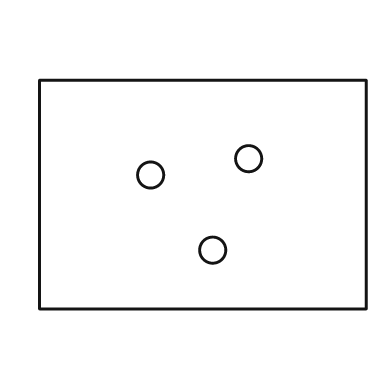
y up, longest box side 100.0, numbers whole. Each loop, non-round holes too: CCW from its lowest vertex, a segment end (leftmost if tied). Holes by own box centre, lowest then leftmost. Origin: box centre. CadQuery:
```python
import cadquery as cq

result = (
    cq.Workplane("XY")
    .moveTo(-50.0, -35.0)
    .lineTo(50.0, -35.0)
    .lineTo(50.0, 35.0)
    .lineTo(-50.0, 35.0)
    .close()
    .moveTo(3.0, -17.0)
    .circle(4.0)
    .moveTo(-16.0, 6.0)
    .circle(4.0)
    .moveTo(14.0, 11.0)
    .circle(4.0)
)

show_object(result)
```